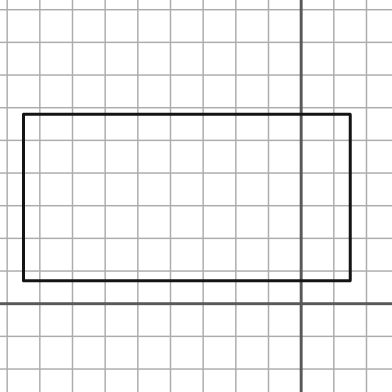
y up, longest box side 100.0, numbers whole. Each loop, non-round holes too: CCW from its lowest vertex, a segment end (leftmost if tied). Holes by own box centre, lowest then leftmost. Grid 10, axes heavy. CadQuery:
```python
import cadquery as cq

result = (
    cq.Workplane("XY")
    .moveTo(-85.0, 7.0)
    .lineTo(15.0, 7.0)
    .lineTo(15.0, 58.0)
    .lineTo(-85.0, 58.0)
    .close()
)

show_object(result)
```